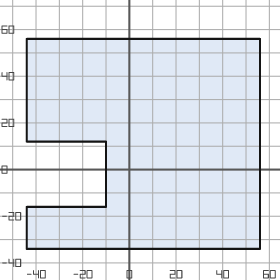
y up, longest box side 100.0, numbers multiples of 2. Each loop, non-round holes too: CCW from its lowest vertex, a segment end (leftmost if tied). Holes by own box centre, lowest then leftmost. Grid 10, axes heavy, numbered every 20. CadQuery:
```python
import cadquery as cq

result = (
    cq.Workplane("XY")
    .moveTo(-44.0, -34.0)
    .lineTo(56.0, -34.0)
    .lineTo(56.0, 56.0)
    .lineTo(-44.0, 56.0)
    .lineTo(-44.0, 12.0)
    .lineTo(-10.0, 12.0)
    .lineTo(-10.0, -16.0)
    .lineTo(-44.0, -16.0)
    .close()
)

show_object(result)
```